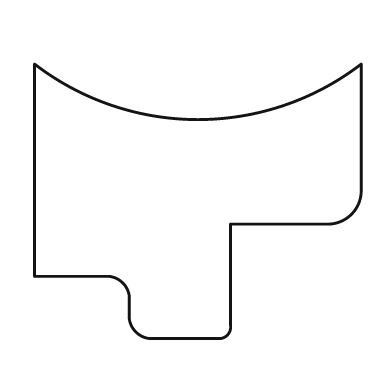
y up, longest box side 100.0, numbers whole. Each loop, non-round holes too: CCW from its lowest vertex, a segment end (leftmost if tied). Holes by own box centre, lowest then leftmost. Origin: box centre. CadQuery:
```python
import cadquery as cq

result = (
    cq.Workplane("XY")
    .moveTo(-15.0, -42.0)
    .lineTo(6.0, -42.0)
    .threePointArc((9.0, -41.0), (10.0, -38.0))
    .lineTo(10.0, -7.0)
    .lineTo(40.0, -7.0)
    .threePointArc((47.0, -4.0), (50.0, 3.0))
    .lineTo(50.0, 42.0)
    .threePointArc((0.0, 25.0), (-50.0, 42.0))
    .lineTo(-50.0, -23.0)
    .lineTo(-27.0, -23.0)
    .threePointArc((-23.0, -25.0), (-21.0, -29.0))
    .lineTo(-21.0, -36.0)
    .threePointArc((-19.0, -40.0), (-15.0, -42.0))
    .close()
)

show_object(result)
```